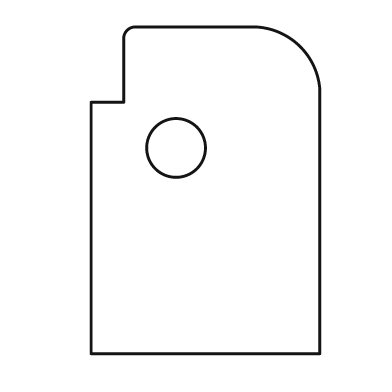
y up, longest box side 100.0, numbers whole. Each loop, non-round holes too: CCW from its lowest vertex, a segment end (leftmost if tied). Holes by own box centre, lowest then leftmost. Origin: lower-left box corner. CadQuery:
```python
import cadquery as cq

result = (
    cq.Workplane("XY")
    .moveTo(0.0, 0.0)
    .lineTo(70.0, 0.0)
    .lineTo(70.0, 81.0)
    .threePointArc((64.0, 94.0), (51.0, 100.0))
    .lineTo(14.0, 100.0)
    .threePointArc((11.0, 99.0), (10.0, 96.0))
    .lineTo(10.0, 77.0)
    .lineTo(0.0, 77.0)
    .close()
    .moveTo(26.0, 63.0)
    .circle(9.0)
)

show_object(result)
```